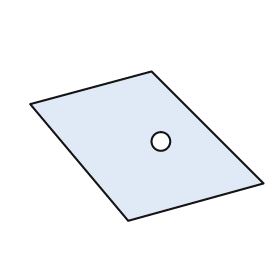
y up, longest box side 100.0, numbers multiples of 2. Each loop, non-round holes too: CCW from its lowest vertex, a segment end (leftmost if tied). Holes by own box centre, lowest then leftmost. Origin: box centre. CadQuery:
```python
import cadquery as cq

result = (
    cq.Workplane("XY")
    .moveTo(-8.0, -32.0)
    .lineTo(50.0, -16.0)
    .lineTo(2.0, 32.0)
    .lineTo(-50.0, 18.0)
    .close()
    .moveTo(6.0, 2.0)
    .circle(4.0)
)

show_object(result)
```